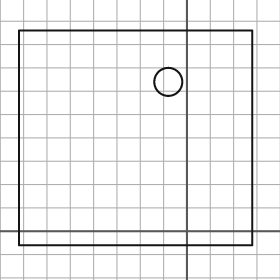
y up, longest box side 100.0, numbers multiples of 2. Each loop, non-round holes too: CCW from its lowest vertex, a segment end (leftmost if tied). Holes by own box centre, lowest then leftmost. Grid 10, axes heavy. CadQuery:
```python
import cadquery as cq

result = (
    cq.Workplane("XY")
    .moveTo(-72.0, -6.0)
    .lineTo(28.0, -6.0)
    .lineTo(28.0, 86.0)
    .lineTo(-72.0, 86.0)
    .close()
    .moveTo(-8.0, 64.0)
    .circle(6.0)
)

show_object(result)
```